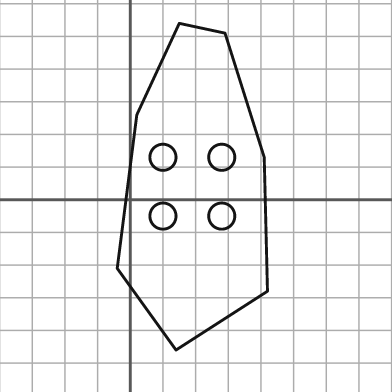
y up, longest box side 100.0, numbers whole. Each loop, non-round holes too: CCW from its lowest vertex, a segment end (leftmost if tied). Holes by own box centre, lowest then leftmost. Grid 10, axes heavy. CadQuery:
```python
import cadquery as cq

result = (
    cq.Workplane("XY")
    .moveTo(14.0, -46.0)
    .lineTo(42.0, -28.0)
    .lineTo(41.0, 13.0)
    .lineTo(29.0, 51.0)
    .lineTo(15.0, 54.0)
    .lineTo(2.0, 26.0)
    .lineTo(-4.0, -21.0)
    .close()
    .moveTo(10.0, -5.0)
    .circle(4.0)
    .moveTo(28.0, -5.0)
    .circle(4.0)
    .moveTo(10.0, 13.0)
    .circle(4.0)
    .moveTo(28.0, 13.0)
    .circle(4.0)
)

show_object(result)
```